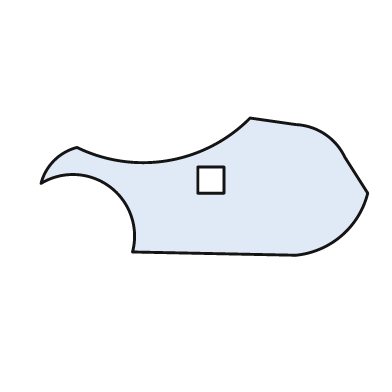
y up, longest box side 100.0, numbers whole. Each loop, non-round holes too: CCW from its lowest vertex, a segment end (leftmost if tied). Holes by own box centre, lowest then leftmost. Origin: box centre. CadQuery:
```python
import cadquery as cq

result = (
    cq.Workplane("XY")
    .moveTo(28.0, -21.0)
    .threePointArc((42.0, -15.0), (50.0, -2.0))
    .lineTo(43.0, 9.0)
    .threePointArc((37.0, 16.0), (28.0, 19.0))
    .lineTo(14.0, 21.0)
    .threePointArc((-11.0, 8.0), (-39.0, 12.0))
    .threePointArc((-46.0, 8.0), (-50.0, 1.0))
    .threePointArc((-29.0, 0.0), (-22.0, -20.0))
    .close()
    .moveTo(-2.0, -2.0)
    .lineTo(6.0, -2.0)
    .lineTo(6.0, 6.0)
    .lineTo(-2.0, 6.0)
    .close()
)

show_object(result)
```